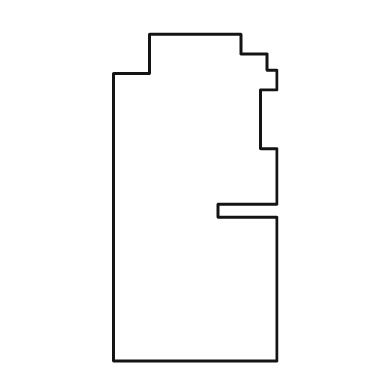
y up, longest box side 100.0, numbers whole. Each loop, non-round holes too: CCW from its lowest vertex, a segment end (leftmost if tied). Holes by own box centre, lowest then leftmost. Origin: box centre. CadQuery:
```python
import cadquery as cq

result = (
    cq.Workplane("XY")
    .moveTo(-25.0, -50.0)
    .lineTo(25.0, -50.0)
    .lineTo(25.0, -6.0)
    .lineTo(7.0, -6.0)
    .lineTo(7.0, -2.0)
    .lineTo(25.0, -2.0)
    .lineTo(25.0, 15.0)
    .lineTo(20.0, 15.0)
    .lineTo(20.0, 33.0)
    .lineTo(25.0, 33.0)
    .lineTo(25.0, 39.0)
    .lineTo(22.0, 39.0)
    .lineTo(22.0, 44.0)
    .lineTo(14.0, 44.0)
    .lineTo(14.0, 50.0)
    .lineTo(-14.0, 50.0)
    .lineTo(-14.0, 38.0)
    .lineTo(-25.0, 38.0)
    .close()
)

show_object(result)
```